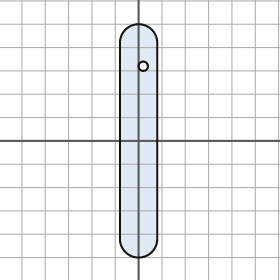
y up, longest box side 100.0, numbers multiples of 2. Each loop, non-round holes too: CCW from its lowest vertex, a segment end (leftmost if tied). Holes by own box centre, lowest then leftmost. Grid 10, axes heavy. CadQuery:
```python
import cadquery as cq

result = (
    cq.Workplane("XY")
    .moveTo(-8.0, -42.0)
    .threePointArc((0.0, -50.0), (8.0, -42.0))
    .lineTo(8.0, 42.0)
    .threePointArc((0.0, 50.0), (-8.0, 42.0))
    .close()
    .moveTo(2.0, 32.0)
    .circle(2.0)
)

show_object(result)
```